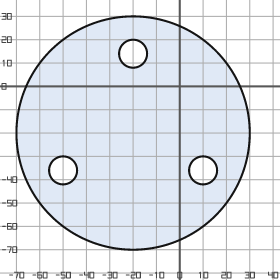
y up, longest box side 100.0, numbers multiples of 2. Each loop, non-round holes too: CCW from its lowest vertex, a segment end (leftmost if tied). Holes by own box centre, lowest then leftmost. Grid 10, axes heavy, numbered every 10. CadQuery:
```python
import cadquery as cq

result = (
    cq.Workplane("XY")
    .moveTo(-20.0, -20.0)
    .circle(50.0)
    .moveTo(-50.0, -36.0)
    .circle(6.0)
    .moveTo(10.0, -36.0)
    .circle(6.0)
    .moveTo(-20.0, 14.0)
    .circle(6.0)
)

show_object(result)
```